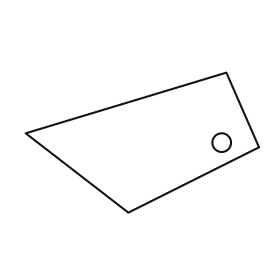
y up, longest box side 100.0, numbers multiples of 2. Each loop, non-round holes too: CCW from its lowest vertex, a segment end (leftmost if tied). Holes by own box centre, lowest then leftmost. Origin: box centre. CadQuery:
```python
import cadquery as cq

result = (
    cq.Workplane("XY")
    .moveTo(-6.0, -30.0)
    .lineTo(50.0, -2.0)
    .lineTo(36.0, 30.0)
    .lineTo(-50.0, 4.0)
    .close()
    .moveTo(34.0, 0.0)
    .circle(4.0)
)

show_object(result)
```